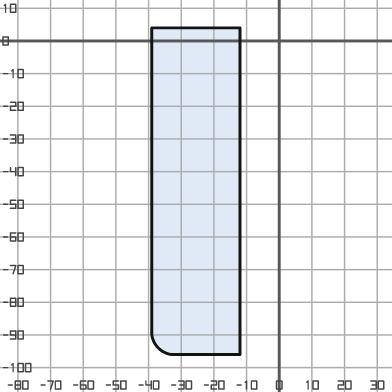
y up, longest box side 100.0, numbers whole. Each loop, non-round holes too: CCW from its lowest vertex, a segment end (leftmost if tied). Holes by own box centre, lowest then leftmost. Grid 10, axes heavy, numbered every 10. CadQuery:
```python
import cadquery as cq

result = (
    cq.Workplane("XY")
    .moveTo(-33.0, -96.0)
    .lineTo(-12.0, -96.0)
    .lineTo(-12.0, 4.0)
    .lineTo(-39.0, 4.0)
    .lineTo(-39.0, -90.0)
    .threePointArc((-37.0, -94.0), (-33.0, -96.0))
    .close()
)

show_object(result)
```